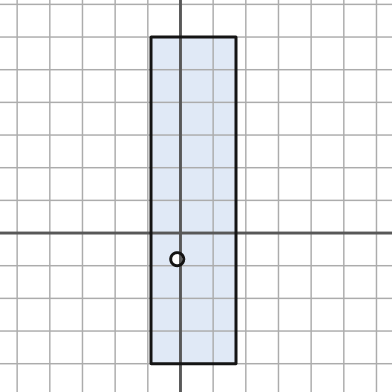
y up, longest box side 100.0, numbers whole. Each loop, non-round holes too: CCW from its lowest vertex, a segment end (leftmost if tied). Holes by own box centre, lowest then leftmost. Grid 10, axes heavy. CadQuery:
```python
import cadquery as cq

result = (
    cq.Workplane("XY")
    .moveTo(-9.0, -40.0)
    .lineTo(17.0, -40.0)
    .lineTo(17.0, 60.0)
    .lineTo(-9.0, 60.0)
    .close()
    .moveTo(-1.0, -8.0)
    .circle(2.0)
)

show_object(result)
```